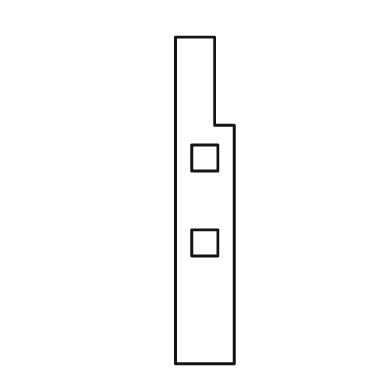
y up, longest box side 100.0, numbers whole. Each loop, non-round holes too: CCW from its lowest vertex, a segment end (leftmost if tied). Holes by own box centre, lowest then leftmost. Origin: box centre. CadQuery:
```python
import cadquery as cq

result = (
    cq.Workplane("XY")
    .moveTo(-9.0, -50.0)
    .lineTo(9.0, -50.0)
    .lineTo(9.0, 23.0)
    .lineTo(3.0, 23.0)
    .lineTo(3.0, 50.0)
    .lineTo(-9.0, 50.0)
    .close()
    .moveTo(-4.0, -17.0)
    .lineTo(4.0, -17.0)
    .lineTo(4.0, -9.0)
    .lineTo(-4.0, -9.0)
    .close()
    .moveTo(-4.0, 9.0)
    .lineTo(4.0, 9.0)
    .lineTo(4.0, 17.0)
    .lineTo(-4.0, 17.0)
    .close()
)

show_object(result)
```